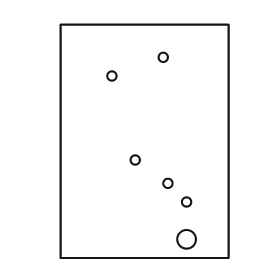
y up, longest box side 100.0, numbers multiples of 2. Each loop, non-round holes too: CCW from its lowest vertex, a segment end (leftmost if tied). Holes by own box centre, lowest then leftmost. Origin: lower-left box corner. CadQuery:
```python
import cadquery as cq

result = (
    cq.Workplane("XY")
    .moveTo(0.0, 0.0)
    .lineTo(72.0, 0.0)
    .lineTo(72.0, 100.0)
    .lineTo(0.0, 100.0)
    .close()
    .moveTo(54.0, 8.0)
    .circle(4.0)
    .moveTo(54.0, 24.0)
    .circle(2.0)
    .moveTo(46.0, 32.0)
    .circle(2.0)
    .moveTo(32.0, 42.0)
    .circle(2.0)
    .moveTo(22.0, 78.0)
    .circle(2.0)
    .moveTo(44.0, 86.0)
    .circle(2.0)
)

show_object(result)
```